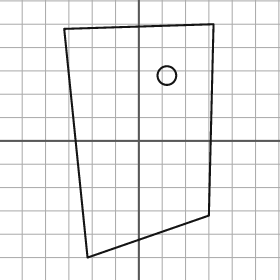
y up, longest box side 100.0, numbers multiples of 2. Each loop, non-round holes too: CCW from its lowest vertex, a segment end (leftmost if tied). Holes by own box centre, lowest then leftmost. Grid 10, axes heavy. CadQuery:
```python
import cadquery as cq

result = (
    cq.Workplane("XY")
    .moveTo(-22.0, -50.0)
    .lineTo(30.0, -32.0)
    .lineTo(32.0, 50.0)
    .lineTo(-32.0, 48.0)
    .close()
    .moveTo(12.0, 28.0)
    .circle(4.0)
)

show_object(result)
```